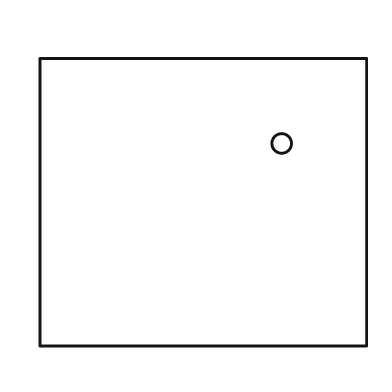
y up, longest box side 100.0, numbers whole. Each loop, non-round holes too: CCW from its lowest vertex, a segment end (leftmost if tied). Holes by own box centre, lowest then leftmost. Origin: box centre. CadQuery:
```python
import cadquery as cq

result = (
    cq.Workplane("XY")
    .moveTo(-50.0, -44.0)
    .lineTo(50.0, -44.0)
    .lineTo(50.0, 44.0)
    .lineTo(-50.0, 44.0)
    .close()
    .moveTo(24.0, 18.0)
    .circle(3.0)
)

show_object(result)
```